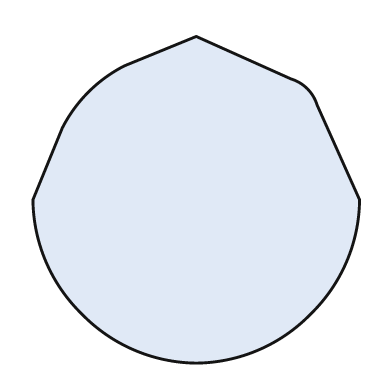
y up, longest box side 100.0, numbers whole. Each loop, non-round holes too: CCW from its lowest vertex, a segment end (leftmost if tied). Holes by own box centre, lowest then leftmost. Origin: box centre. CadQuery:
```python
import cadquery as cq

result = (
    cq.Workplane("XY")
    .moveTo(0.0, -50.0)
    .threePointArc((19.0, -46.0), (35.0, -35.0))
    .threePointArc((46.0, -19.0), (50.0, 0.0))
    .lineTo(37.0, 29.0)
    .threePointArc((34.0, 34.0), (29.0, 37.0))
    .lineTo(0.0, 50.0)
    .lineTo(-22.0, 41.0)
    .threePointArc((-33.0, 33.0), (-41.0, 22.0))
    .lineTo(-50.0, 0.0)
    .threePointArc((-46.0, -19.0), (-35.0, -35.0))
    .threePointArc((-19.0, -46.0), (0.0, -50.0))
    .close()
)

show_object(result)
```